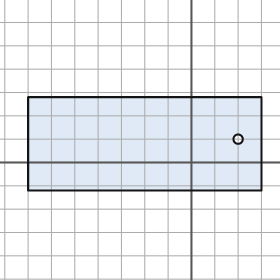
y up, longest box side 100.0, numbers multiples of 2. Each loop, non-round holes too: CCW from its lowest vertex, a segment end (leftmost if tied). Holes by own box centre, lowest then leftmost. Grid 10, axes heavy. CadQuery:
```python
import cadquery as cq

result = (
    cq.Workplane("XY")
    .moveTo(-70.0, -12.0)
    .lineTo(30.0, -12.0)
    .lineTo(30.0, 28.0)
    .lineTo(-70.0, 28.0)
    .close()
    .moveTo(20.0, 10.0)
    .circle(2.0)
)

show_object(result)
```